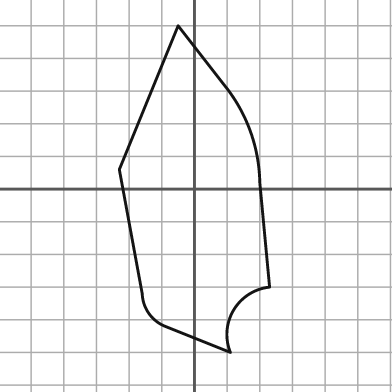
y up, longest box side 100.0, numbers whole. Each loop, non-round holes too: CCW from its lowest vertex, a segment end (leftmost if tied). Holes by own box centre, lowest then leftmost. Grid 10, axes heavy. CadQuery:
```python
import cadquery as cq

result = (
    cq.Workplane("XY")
    .moveTo(11.0, -50.0)
    .threePointArc((12.0, -37.0), (23.0, -30.0))
    .lineTo(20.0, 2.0)
    .threePointArc((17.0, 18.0), (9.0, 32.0))
    .lineTo(-5.0, 50.0)
    .lineTo(-23.0, 6.0)
    .lineTo(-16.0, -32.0)
    .threePointArc((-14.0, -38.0), (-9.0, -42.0))
    .close()
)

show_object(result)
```